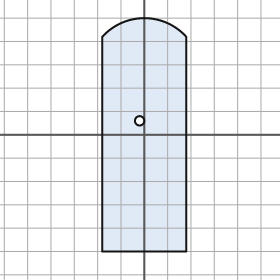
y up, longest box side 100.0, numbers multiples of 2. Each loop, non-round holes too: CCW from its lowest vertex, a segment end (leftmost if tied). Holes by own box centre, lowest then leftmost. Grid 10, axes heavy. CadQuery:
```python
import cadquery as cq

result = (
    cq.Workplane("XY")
    .moveTo(-18.0, -50.0)
    .lineTo(18.0, -50.0)
    .lineTo(18.0, 42.0)
    .threePointArc((0.0, 50.0), (-18.0, 42.0))
    .close()
    .moveTo(-2.0, 6.0)
    .circle(2.0)
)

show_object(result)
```